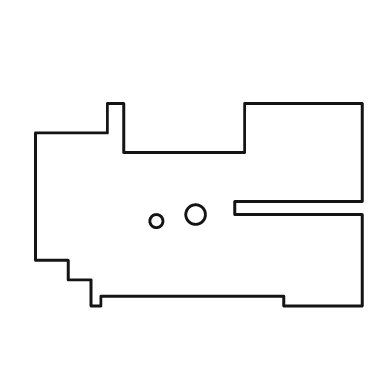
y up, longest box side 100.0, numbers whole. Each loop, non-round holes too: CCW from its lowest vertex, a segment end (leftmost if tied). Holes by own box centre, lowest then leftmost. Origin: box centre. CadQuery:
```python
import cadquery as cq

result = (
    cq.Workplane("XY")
    .moveTo(-33.0, -31.0)
    .lineTo(-30.0, -31.0)
    .lineTo(-30.0, -28.0)
    .lineTo(26.0, -28.0)
    .lineTo(26.0, -31.0)
    .lineTo(50.0, -31.0)
    .lineTo(50.0, -3.0)
    .lineTo(11.0, -3.0)
    .lineTo(11.0, 1.0)
    .lineTo(50.0, 1.0)
    .lineTo(50.0, 31.0)
    .lineTo(14.0, 31.0)
    .lineTo(14.0, 16.0)
    .lineTo(-23.0, 16.0)
    .lineTo(-23.0, 31.0)
    .lineTo(-28.0, 31.0)
    .lineTo(-28.0, 22.0)
    .lineTo(-50.0, 22.0)
    .lineTo(-50.0, -17.0)
    .lineTo(-40.0, -17.0)
    .lineTo(-40.0, -23.0)
    .lineTo(-33.0, -23.0)
    .close()
    .moveTo(-13.0, -5.0)
    .circle(2.0)
    .moveTo(-1.0, -3.0)
    .circle(3.0)
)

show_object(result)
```